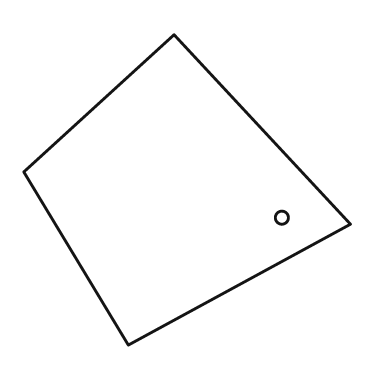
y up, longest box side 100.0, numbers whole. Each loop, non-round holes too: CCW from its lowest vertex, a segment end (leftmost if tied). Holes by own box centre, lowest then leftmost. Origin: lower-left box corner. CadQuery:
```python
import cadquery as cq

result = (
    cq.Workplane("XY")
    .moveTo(32.0, 0.0)
    .lineTo(100.0, 37.0)
    .lineTo(46.0, 95.0)
    .lineTo(0.0, 53.0)
    .close()
    .moveTo(79.0, 39.0)
    .circle(2.0)
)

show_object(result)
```